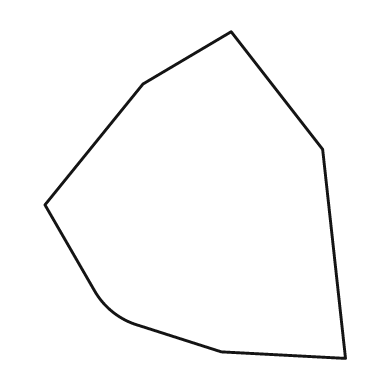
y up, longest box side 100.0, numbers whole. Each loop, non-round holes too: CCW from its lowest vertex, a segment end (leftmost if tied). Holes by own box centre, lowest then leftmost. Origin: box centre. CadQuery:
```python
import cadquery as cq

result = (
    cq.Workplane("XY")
    .moveTo(46.0, -50.0)
    .lineTo(39.0, 14.0)
    .lineTo(11.0, 50.0)
    .lineTo(-16.0, 34.0)
    .lineTo(-46.0, -3.0)
    .lineTo(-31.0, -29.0)
    .threePointArc((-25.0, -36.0), (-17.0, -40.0))
    .lineTo(8.0, -48.0)
    .close()
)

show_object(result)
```